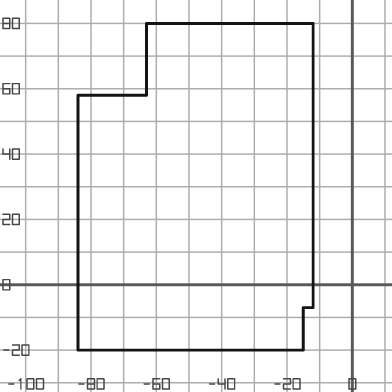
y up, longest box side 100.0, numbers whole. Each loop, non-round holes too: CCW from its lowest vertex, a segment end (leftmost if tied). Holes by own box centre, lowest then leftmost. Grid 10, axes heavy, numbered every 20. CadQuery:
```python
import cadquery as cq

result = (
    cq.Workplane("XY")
    .moveTo(-84.0, -20.0)
    .lineTo(-15.0, -20.0)
    .lineTo(-15.0, -7.0)
    .lineTo(-12.0, -7.0)
    .lineTo(-12.0, 80.0)
    .lineTo(-63.0, 80.0)
    .lineTo(-63.0, 58.0)
    .lineTo(-84.0, 58.0)
    .close()
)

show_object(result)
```